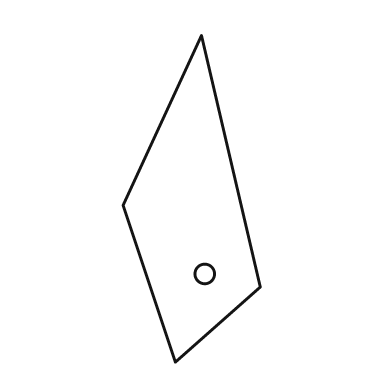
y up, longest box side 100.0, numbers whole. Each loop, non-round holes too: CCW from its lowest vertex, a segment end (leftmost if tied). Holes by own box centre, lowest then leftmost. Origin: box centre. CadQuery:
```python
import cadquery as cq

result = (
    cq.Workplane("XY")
    .moveTo(-5.0, -50.0)
    .lineTo(21.0, -27.0)
    .lineTo(3.0, 50.0)
    .lineTo(-21.0, -2.0)
    .close()
    .moveTo(4.0, -23.0)
    .circle(3.0)
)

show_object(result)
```